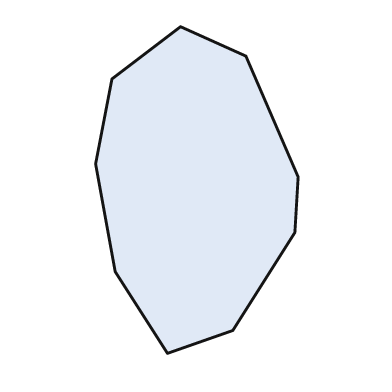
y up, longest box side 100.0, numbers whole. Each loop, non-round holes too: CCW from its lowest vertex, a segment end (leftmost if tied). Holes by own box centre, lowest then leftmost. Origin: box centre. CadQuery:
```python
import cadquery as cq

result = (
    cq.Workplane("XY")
    .moveTo(-9.0, -50.0)
    .lineTo(11.0, -43.0)
    .lineTo(30.0, -13.0)
    .lineTo(31.0, 4.0)
    .lineTo(15.0, 41.0)
    .lineTo(-5.0, 50.0)
    .lineTo(-26.0, 34.0)
    .lineTo(-31.0, 8.0)
    .lineTo(-25.0, -25.0)
    .close()
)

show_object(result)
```